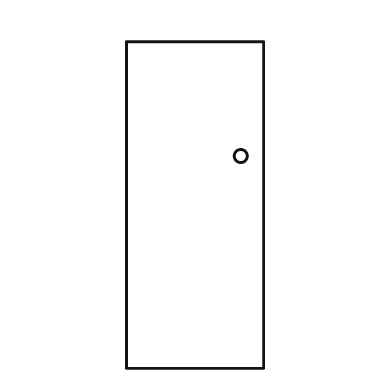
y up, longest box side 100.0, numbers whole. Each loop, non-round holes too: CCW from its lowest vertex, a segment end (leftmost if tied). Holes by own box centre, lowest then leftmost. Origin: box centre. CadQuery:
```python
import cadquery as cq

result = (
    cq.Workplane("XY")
    .moveTo(-21.0, -50.0)
    .lineTo(21.0, -50.0)
    .lineTo(21.0, 50.0)
    .lineTo(-21.0, 50.0)
    .close()
    .moveTo(14.0, 15.0)
    .circle(2.0)
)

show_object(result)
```